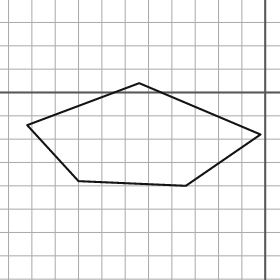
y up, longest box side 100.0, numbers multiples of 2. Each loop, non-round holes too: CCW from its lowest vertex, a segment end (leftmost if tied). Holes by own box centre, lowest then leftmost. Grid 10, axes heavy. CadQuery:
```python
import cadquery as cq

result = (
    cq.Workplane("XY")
    .moveTo(-34.0, -40.0)
    .lineTo(-2.0, -18.0)
    .lineTo(-54.0, 4.0)
    .lineTo(-102.0, -14.0)
    .lineTo(-80.0, -38.0)
    .close()
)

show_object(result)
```